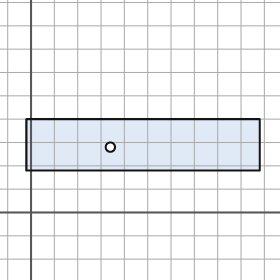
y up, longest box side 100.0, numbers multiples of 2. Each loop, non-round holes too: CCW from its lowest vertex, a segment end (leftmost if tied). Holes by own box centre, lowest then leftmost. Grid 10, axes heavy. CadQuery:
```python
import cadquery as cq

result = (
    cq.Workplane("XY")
    .moveTo(-2.0, 18.0)
    .lineTo(98.0, 18.0)
    .lineTo(98.0, 40.0)
    .lineTo(-2.0, 40.0)
    .close()
    .moveTo(34.0, 28.0)
    .circle(2.0)
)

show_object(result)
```